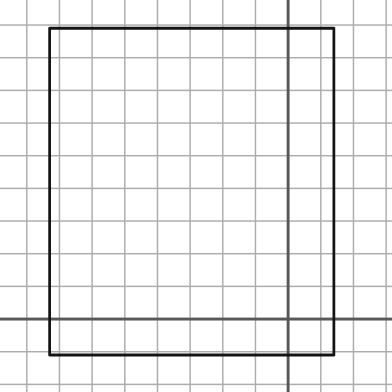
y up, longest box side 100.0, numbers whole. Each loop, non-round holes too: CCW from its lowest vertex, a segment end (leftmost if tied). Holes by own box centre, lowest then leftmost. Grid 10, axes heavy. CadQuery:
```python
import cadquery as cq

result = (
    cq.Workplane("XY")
    .moveTo(-73.0, -11.0)
    .lineTo(14.0, -11.0)
    .lineTo(14.0, 89.0)
    .lineTo(-73.0, 89.0)
    .close()
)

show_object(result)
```